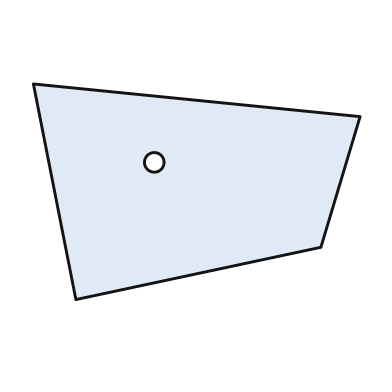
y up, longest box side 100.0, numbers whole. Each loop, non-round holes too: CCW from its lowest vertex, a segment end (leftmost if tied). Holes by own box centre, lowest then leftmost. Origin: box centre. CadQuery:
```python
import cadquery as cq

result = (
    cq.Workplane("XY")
    .moveTo(-37.0, -33.0)
    .lineTo(38.0, -17.0)
    .lineTo(50.0, 23.0)
    .lineTo(-50.0, 33.0)
    .close()
    .moveTo(-13.0, 9.0)
    .circle(3.0)
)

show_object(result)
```